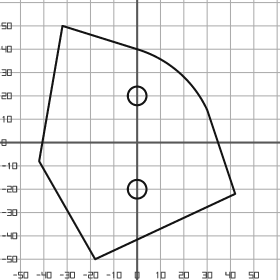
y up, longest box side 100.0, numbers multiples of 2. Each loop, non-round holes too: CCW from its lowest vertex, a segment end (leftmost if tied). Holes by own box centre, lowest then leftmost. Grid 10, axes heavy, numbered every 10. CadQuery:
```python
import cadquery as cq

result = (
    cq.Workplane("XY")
    .moveTo(-18.0, -50.0)
    .lineTo(42.0, -22.0)
    .lineTo(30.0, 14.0)
    .threePointArc((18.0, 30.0), (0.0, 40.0))
    .lineTo(-32.0, 50.0)
    .lineTo(-42.0, -8.0)
    .close()
    .moveTo(0.0, -20.0)
    .circle(4.0)
    .moveTo(0.0, 20.0)
    .circle(4.0)
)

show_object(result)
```